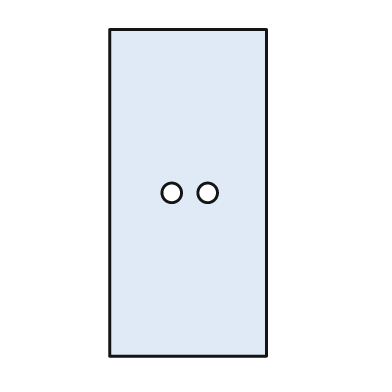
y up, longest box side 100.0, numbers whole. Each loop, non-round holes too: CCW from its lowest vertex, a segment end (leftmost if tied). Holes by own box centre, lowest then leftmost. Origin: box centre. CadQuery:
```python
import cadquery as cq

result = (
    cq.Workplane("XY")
    .moveTo(-24.0, -50.0)
    .lineTo(24.0, -50.0)
    .lineTo(24.0, 50.0)
    .lineTo(-24.0, 50.0)
    .close()
    .moveTo(-5.0, 0.0)
    .circle(3.0)
    .moveTo(6.0, 0.0)
    .circle(3.0)
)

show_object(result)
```